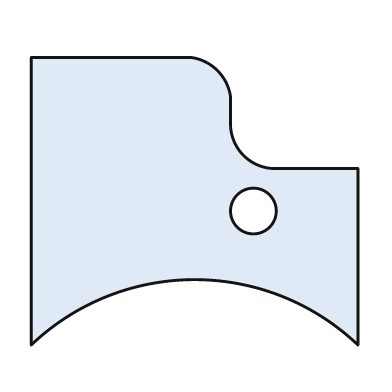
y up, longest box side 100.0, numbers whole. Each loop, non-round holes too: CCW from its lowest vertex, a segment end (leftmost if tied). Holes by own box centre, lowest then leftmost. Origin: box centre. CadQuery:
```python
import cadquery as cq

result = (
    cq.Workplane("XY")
    .moveTo(-50.0, -44.0)
    .threePointArc((0.0, -24.0), (50.0, -44.0))
    .lineTo(50.0, 10.0)
    .lineTo(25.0, 10.0)
    .threePointArc((15.0, 14.0), (11.0, 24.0))
    .lineTo(11.0, 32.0)
    .threePointArc((7.0, 40.0), (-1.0, 44.0))
    .lineTo(-50.0, 44.0)
    .close()
    .moveTo(18.0, -3.0)
    .circle(7.0)
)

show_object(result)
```